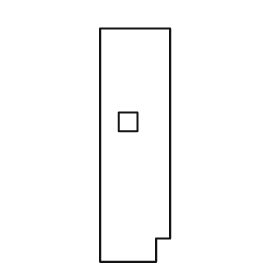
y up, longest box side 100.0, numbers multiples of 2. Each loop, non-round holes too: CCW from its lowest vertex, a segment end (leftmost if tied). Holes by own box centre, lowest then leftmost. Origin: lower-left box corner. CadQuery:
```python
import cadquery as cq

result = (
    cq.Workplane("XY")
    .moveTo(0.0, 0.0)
    .lineTo(24.0, 0.0)
    .lineTo(24.0, 10.0)
    .lineTo(30.0, 10.0)
    .lineTo(30.0, 100.0)
    .lineTo(0.0, 100.0)
    .close()
    .moveTo(8.0, 56.0)
    .lineTo(16.0, 56.0)
    .lineTo(16.0, 64.0)
    .lineTo(8.0, 64.0)
    .close()
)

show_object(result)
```